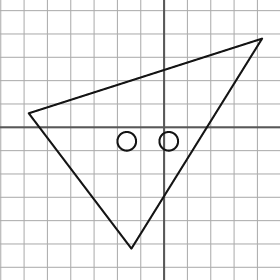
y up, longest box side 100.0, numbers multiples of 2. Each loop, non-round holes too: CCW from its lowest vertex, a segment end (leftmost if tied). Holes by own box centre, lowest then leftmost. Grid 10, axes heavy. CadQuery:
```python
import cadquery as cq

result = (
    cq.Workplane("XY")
    .moveTo(-14.0, -52.0)
    .lineTo(42.0, 38.0)
    .lineTo(-58.0, 6.0)
    .close()
    .moveTo(-16.0, -6.0)
    .circle(4.0)
    .moveTo(2.0, -6.0)
    .circle(4.0)
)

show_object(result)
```